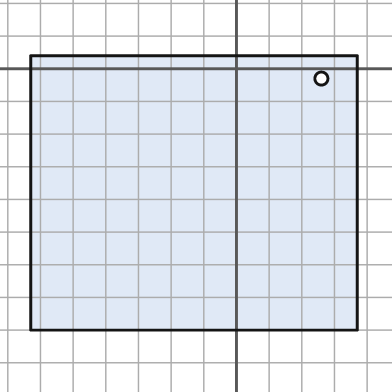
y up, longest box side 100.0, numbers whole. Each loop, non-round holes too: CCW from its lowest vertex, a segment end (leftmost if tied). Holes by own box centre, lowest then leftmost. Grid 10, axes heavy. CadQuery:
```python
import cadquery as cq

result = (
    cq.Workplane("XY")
    .moveTo(-63.0, -80.0)
    .lineTo(37.0, -80.0)
    .lineTo(37.0, 4.0)
    .lineTo(-63.0, 4.0)
    .close()
    .moveTo(26.0, -3.0)
    .circle(2.0)
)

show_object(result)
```